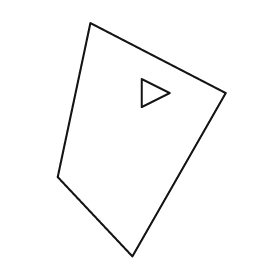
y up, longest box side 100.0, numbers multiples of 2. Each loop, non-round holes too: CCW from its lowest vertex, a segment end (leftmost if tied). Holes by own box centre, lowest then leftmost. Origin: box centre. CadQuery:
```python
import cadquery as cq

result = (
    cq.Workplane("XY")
    .moveTo(-4.0, -50.0)
    .lineTo(36.0, 20.0)
    .lineTo(-22.0, 50.0)
    .lineTo(-36.0, -16.0)
    .close()
    .moveTo(0.0, 14.0)
    .lineTo(12.0, 20.0)
    .lineTo(0.0, 26.0)
    .close()
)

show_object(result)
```